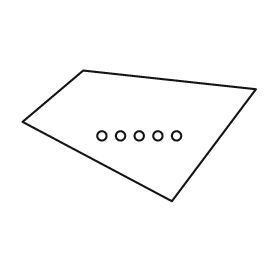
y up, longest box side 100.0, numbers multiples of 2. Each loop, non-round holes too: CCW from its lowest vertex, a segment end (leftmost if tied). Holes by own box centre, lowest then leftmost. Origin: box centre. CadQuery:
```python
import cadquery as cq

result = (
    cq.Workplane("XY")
    .moveTo(14.0, -28.0)
    .lineTo(50.0, 20.0)
    .lineTo(-24.0, 28.0)
    .lineTo(-50.0, 6.0)
    .close()
    .moveTo(-16.0, 0.0)
    .circle(2.0)
    .moveTo(-8.0, 0.0)
    .circle(2.0)
    .moveTo(0.0, 0.0)
    .circle(2.0)
    .moveTo(8.0, 0.0)
    .circle(2.0)
    .moveTo(16.0, 0.0)
    .circle(2.0)
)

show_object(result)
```